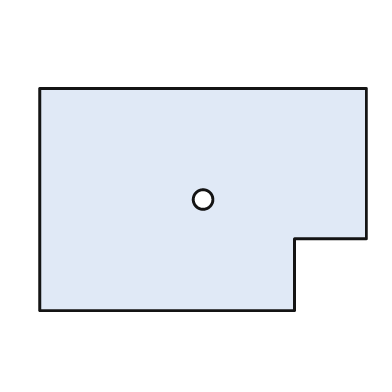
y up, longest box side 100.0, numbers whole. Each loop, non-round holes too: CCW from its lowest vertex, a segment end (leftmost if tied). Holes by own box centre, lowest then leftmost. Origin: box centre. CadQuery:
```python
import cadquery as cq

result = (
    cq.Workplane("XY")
    .moveTo(-50.0, -34.0)
    .lineTo(28.0, -34.0)
    .lineTo(28.0, -12.0)
    .lineTo(50.0, -12.0)
    .lineTo(50.0, 34.0)
    .lineTo(-50.0, 34.0)
    .close()
    .moveTo(0.0, 0.0)
    .circle(3.0)
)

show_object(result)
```